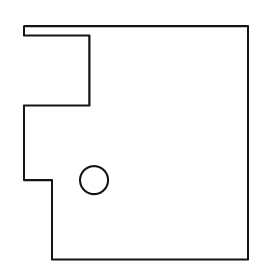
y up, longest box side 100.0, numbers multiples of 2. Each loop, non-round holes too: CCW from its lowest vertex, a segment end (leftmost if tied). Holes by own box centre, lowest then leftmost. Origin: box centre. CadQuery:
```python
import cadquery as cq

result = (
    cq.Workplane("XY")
    .moveTo(-36.0, -50.0)
    .lineTo(48.0, -50.0)
    .lineTo(48.0, 50.0)
    .lineTo(-48.0, 50.0)
    .lineTo(-48.0, 46.0)
    .lineTo(-20.0, 46.0)
    .lineTo(-20.0, 16.0)
    .lineTo(-48.0, 16.0)
    .lineTo(-48.0, -16.0)
    .lineTo(-36.0, -16.0)
    .close()
    .moveTo(-18.0, -16.0)
    .circle(6.0)
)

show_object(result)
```